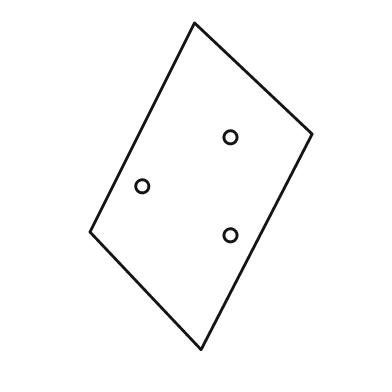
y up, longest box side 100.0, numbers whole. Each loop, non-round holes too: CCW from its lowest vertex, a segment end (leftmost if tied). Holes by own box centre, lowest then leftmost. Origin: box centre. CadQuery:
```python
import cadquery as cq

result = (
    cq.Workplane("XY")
    .moveTo(0.0, -50.0)
    .lineTo(34.0, 16.0)
    .lineTo(-2.0, 50.0)
    .lineTo(-34.0, -14.0)
    .close()
    .moveTo(9.0, -15.0)
    .circle(2.0)
    .moveTo(-18.0, 0.0)
    .circle(2.0)
    .moveTo(9.0, 15.0)
    .circle(2.0)
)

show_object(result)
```